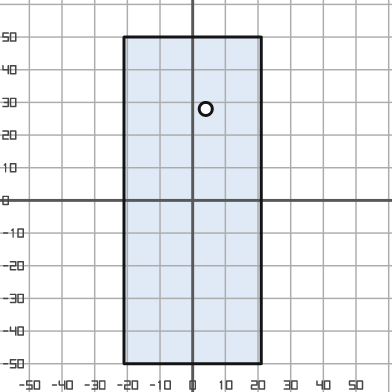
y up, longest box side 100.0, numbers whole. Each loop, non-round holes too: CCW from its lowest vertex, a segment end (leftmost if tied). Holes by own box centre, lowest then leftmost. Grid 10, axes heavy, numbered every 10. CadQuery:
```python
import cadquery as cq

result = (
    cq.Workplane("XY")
    .moveTo(-21.0, -50.0)
    .lineTo(21.0, -50.0)
    .lineTo(21.0, 50.0)
    .lineTo(-21.0, 50.0)
    .close()
    .moveTo(4.0, 28.0)
    .circle(2.0)
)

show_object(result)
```